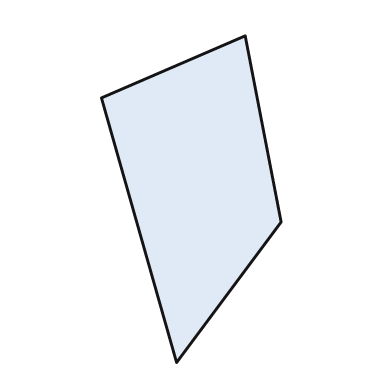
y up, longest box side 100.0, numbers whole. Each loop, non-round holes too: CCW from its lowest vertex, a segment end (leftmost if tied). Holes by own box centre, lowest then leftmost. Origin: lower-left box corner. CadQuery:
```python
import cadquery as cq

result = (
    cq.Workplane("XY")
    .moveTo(23.0, 0.0)
    .lineTo(55.0, 43.0)
    .lineTo(44.0, 100.0)
    .lineTo(0.0, 81.0)
    .close()
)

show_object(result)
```